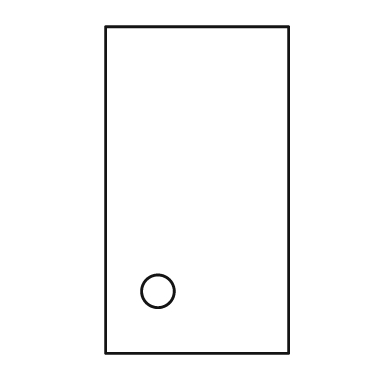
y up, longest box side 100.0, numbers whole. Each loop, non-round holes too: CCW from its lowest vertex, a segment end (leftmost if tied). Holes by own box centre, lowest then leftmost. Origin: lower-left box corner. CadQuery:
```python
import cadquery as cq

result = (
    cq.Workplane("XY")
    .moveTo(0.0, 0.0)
    .lineTo(56.0, 0.0)
    .lineTo(56.0, 100.0)
    .lineTo(0.0, 100.0)
    .close()
    .moveTo(16.0, 19.0)
    .circle(5.0)
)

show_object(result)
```